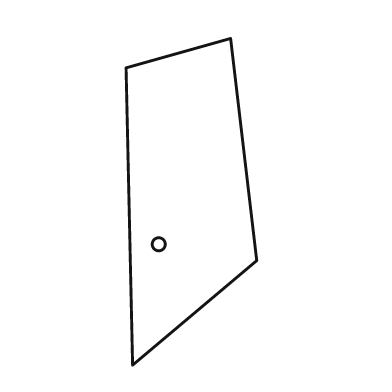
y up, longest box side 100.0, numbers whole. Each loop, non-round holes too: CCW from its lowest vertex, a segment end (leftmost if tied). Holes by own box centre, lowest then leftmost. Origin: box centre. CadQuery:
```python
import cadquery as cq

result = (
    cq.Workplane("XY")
    .moveTo(-18.0, -50.0)
    .lineTo(20.0, -18.0)
    .lineTo(12.0, 50.0)
    .lineTo(-20.0, 41.0)
    .close()
    .moveTo(-10.0, -13.0)
    .circle(2.0)
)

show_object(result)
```